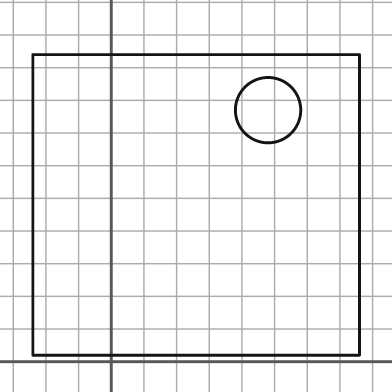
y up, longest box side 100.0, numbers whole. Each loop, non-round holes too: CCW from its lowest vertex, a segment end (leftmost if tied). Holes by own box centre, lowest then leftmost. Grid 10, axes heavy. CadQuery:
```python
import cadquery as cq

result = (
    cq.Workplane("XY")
    .moveTo(-24.0, 2.0)
    .lineTo(76.0, 2.0)
    .lineTo(76.0, 94.0)
    .lineTo(-24.0, 94.0)
    .close()
    .moveTo(48.0, 77.0)
    .circle(10.0)
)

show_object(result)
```